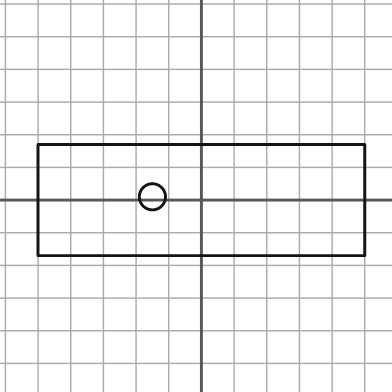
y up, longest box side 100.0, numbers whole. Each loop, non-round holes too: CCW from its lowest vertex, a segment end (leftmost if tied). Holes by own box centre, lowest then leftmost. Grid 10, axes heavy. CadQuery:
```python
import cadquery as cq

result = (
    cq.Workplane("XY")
    .moveTo(-50.0, -17.0)
    .lineTo(50.0, -17.0)
    .lineTo(50.0, 17.0)
    .lineTo(-50.0, 17.0)
    .close()
    .moveTo(-15.0, 1.0)
    .circle(4.0)
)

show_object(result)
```